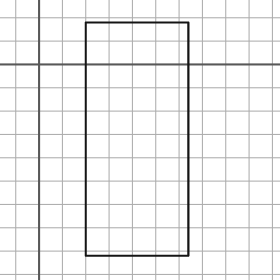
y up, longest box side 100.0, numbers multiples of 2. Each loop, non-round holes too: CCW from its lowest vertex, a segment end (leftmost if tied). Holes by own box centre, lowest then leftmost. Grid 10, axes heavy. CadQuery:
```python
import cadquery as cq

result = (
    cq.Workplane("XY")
    .moveTo(20.0, -82.0)
    .lineTo(64.0, -82.0)
    .lineTo(64.0, 18.0)
    .lineTo(20.0, 18.0)
    .close()
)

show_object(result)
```